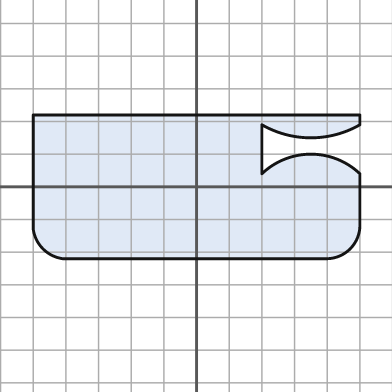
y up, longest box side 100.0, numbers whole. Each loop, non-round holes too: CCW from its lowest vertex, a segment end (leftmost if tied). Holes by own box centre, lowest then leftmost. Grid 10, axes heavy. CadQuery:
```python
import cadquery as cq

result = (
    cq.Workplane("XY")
    .moveTo(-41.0, -22.0)
    .lineTo(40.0, -22.0)
    .threePointArc((47.0, -19.0), (50.0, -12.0))
    .lineTo(50.0, 4.0)
    .threePointArc((35.0, 10.0), (20.0, 4.0))
    .lineTo(20.0, 19.0)
    .threePointArc((35.0, 15.0), (50.0, 19.0))
    .lineTo(50.0, 22.0)
    .lineTo(-50.0, 22.0)
    .lineTo(-50.0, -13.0)
    .threePointArc((-47.0, -19.0), (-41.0, -22.0))
    .close()
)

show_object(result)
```